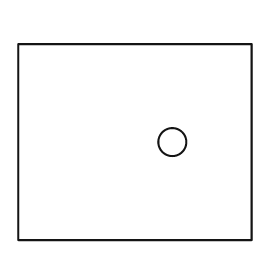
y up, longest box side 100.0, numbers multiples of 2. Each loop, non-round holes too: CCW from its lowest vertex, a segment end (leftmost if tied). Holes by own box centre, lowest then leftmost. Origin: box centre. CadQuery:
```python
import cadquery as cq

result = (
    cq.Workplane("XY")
    .moveTo(-50.0, -42.0)
    .lineTo(50.0, -42.0)
    .lineTo(50.0, 42.0)
    .lineTo(-50.0, 42.0)
    .close()
    .moveTo(16.0, 0.0)
    .circle(6.0)
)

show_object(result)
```